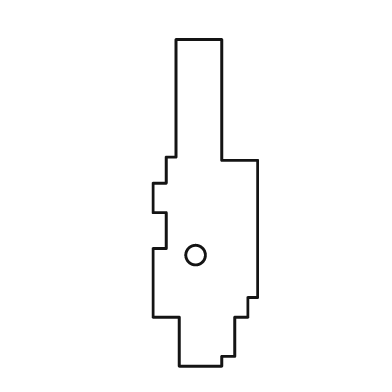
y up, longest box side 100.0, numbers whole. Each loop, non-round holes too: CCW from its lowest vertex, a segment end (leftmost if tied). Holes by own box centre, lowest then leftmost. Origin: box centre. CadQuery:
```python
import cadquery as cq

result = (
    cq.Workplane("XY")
    .moveTo(-8.0, -50.0)
    .lineTo(5.0, -50.0)
    .lineTo(5.0, -47.0)
    .lineTo(9.0, -47.0)
    .lineTo(9.0, -35.0)
    .lineTo(13.0, -35.0)
    .lineTo(13.0, -29.0)
    .lineTo(16.0, -29.0)
    .lineTo(16.0, 13.0)
    .lineTo(5.0, 13.0)
    .lineTo(5.0, 50.0)
    .lineTo(-9.0, 50.0)
    .lineTo(-9.0, 14.0)
    .lineTo(-12.0, 14.0)
    .lineTo(-12.0, 6.0)
    .lineTo(-16.0, 6.0)
    .lineTo(-16.0, -3.0)
    .lineTo(-12.0, -3.0)
    .lineTo(-12.0, -14.0)
    .lineTo(-16.0, -14.0)
    .lineTo(-16.0, -35.0)
    .lineTo(-8.0, -35.0)
    .close()
    .moveTo(-3.0, -16.0)
    .circle(3.0)
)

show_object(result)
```